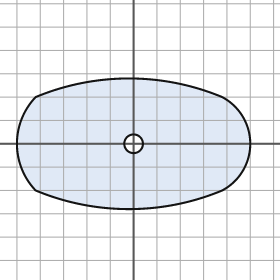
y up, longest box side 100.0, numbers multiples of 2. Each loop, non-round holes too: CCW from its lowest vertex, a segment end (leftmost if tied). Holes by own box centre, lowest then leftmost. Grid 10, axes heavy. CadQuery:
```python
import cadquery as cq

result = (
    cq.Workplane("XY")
    .moveTo(-42.0, -20.0)
    .threePointArc((-2.0, -28.0), (38.0, -20.0))
    .threePointArc((50.0, 0.0), (38.0, 20.0))
    .threePointArc((-2.0, 28.0), (-42.0, 20.0))
    .threePointArc((-50.0, 0.0), (-42.0, -20.0))
    .close()
    .moveTo(0.0, 0.0)
    .circle(4.0)
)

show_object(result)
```